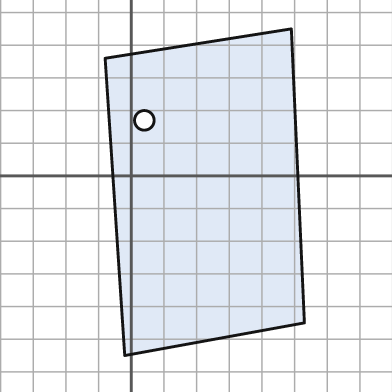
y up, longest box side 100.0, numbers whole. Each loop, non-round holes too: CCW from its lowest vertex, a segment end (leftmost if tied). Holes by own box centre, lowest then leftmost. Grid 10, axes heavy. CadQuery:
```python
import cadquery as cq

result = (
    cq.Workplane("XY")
    .moveTo(-2.0, -55.0)
    .lineTo(53.0, -45.0)
    .lineTo(49.0, 45.0)
    .lineTo(-8.0, 36.0)
    .close()
    .moveTo(4.0, 17.0)
    .circle(3.0)
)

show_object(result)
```